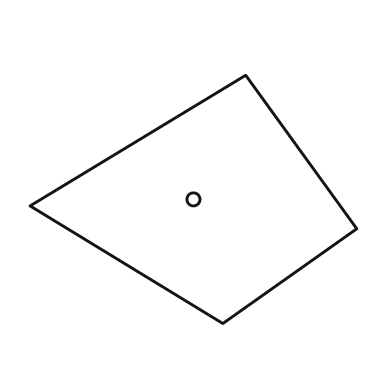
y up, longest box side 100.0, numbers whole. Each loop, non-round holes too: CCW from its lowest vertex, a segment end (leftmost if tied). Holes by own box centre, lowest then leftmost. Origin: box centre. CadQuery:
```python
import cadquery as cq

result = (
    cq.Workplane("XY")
    .moveTo(9.0, -38.0)
    .lineTo(50.0, -9.0)
    .lineTo(16.0, 38.0)
    .lineTo(-50.0, -2.0)
    .close()
    .moveTo(0.0, 0.0)
    .circle(2.0)
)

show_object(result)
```